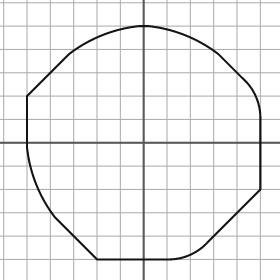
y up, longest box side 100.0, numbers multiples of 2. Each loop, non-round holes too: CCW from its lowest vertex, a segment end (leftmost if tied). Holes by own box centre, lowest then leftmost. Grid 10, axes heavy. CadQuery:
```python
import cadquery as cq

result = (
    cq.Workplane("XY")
    .moveTo(-20.0, -50.0)
    .lineTo(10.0, -50.0)
    .threePointArc((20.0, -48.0), (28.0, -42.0))
    .lineTo(50.0, -20.0)
    .lineTo(50.0, 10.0)
    .threePointArc((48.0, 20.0), (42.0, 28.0))
    .lineTo(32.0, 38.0)
    .threePointArc((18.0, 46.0), (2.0, 50.0))
    .lineTo(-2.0, 50.0)
    .threePointArc((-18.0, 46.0), (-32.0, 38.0))
    .lineTo(-50.0, 20.0)
    .lineTo(-50.0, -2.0)
    .threePointArc((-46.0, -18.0), (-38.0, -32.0))
    .close()
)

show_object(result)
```